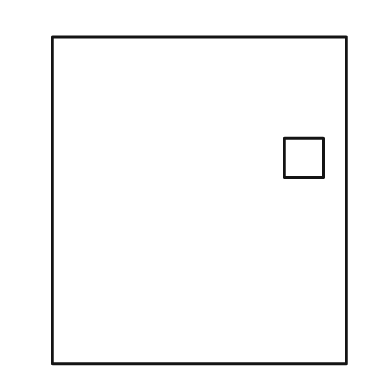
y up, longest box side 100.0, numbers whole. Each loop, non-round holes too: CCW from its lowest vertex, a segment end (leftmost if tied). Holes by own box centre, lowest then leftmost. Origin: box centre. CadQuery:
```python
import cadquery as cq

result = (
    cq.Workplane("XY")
    .moveTo(-45.0, -50.0)
    .lineTo(45.0, -50.0)
    .lineTo(45.0, 50.0)
    .lineTo(-45.0, 50.0)
    .close()
    .moveTo(26.0, 7.0)
    .lineTo(38.0, 7.0)
    .lineTo(38.0, 19.0)
    .lineTo(26.0, 19.0)
    .close()
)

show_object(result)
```